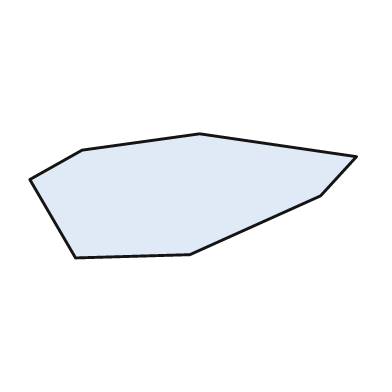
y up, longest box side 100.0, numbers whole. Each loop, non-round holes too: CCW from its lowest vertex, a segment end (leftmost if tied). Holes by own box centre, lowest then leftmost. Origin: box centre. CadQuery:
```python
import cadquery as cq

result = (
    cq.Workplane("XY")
    .moveTo(-36.0, -19.0)
    .lineTo(-1.0, -18.0)
    .lineTo(39.0, 0.0)
    .lineTo(50.0, 12.0)
    .lineTo(2.0, 19.0)
    .lineTo(-34.0, 14.0)
    .lineTo(-50.0, 5.0)
    .close()
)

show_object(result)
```